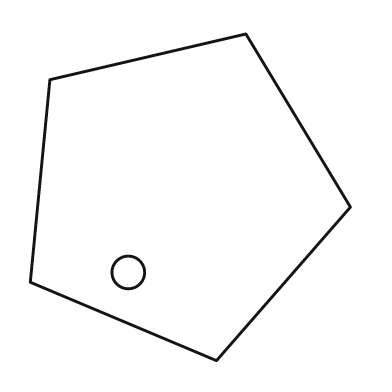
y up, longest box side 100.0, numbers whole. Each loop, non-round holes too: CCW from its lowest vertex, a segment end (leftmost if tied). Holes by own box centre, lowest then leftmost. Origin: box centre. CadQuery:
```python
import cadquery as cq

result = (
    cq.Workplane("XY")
    .moveTo(8.0, -50.0)
    .lineTo(49.0, -3.0)
    .lineTo(17.0, 50.0)
    .lineTo(-43.0, 36.0)
    .lineTo(-49.0, -26.0)
    .close()
    .moveTo(-19.0, -23.0)
    .circle(5.0)
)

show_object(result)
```